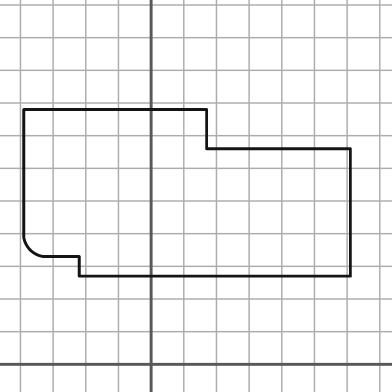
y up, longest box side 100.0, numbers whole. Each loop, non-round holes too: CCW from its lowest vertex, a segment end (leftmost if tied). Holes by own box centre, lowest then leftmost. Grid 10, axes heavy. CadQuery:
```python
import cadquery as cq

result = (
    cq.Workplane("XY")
    .moveTo(-22.0, 27.0)
    .lineTo(61.0, 27.0)
    .lineTo(61.0, 66.0)
    .lineTo(17.0, 66.0)
    .lineTo(17.0, 78.0)
    .lineTo(-39.0, 78.0)
    .lineTo(-39.0, 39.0)
    .threePointArc((-37.0, 35.0), (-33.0, 33.0))
    .lineTo(-22.0, 33.0)
    .close()
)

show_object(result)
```